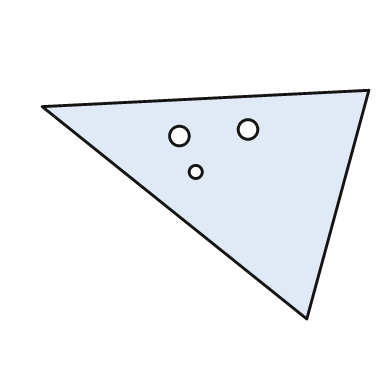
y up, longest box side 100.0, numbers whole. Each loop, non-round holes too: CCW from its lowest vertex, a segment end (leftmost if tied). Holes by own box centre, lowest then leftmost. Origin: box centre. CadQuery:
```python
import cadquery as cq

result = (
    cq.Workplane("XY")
    .moveTo(31.0, -35.0)
    .lineTo(50.0, 35.0)
    .lineTo(-50.0, 30.0)
    .close()
    .moveTo(-3.0, 10.0)
    .circle(2.0)
    .moveTo(-8.0, 21.0)
    .circle(3.0)
    .moveTo(13.0, 23.0)
    .circle(3.0)
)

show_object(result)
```